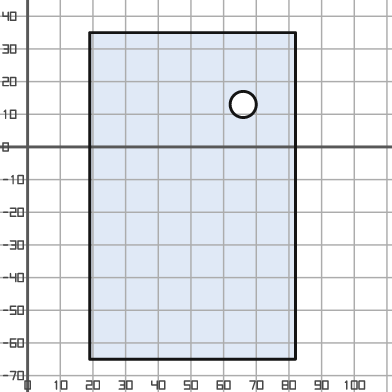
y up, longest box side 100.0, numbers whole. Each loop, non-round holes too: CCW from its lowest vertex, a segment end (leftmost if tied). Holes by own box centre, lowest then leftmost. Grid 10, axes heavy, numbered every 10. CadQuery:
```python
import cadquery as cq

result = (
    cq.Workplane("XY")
    .moveTo(19.0, -65.0)
    .lineTo(82.0, -65.0)
    .lineTo(82.0, 35.0)
    .lineTo(19.0, 35.0)
    .close()
    .moveTo(66.0, 13.0)
    .circle(4.0)
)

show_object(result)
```